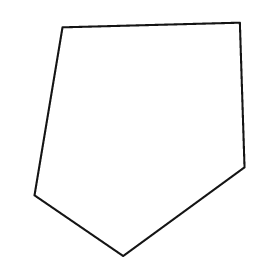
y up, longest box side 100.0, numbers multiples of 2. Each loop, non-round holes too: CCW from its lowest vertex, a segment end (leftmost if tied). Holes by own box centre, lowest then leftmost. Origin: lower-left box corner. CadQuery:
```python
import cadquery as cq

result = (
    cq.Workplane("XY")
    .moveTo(38.0, 0.0)
    .lineTo(90.0, 38.0)
    .lineTo(88.0, 100.0)
    .lineTo(12.0, 98.0)
    .lineTo(0.0, 26.0)
    .close()
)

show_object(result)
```